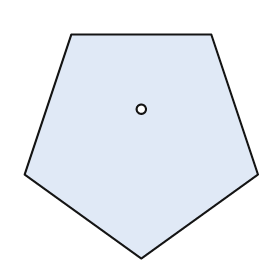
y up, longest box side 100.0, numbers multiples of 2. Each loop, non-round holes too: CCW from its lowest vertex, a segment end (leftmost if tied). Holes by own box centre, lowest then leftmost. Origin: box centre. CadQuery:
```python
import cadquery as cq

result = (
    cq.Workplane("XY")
    .moveTo(0.0, -48.0)
    .lineTo(50.0, -12.0)
    .lineTo(30.0, 48.0)
    .lineTo(-30.0, 48.0)
    .lineTo(-50.0, -12.0)
    .close()
    .moveTo(0.0, 16.0)
    .circle(2.0)
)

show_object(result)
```